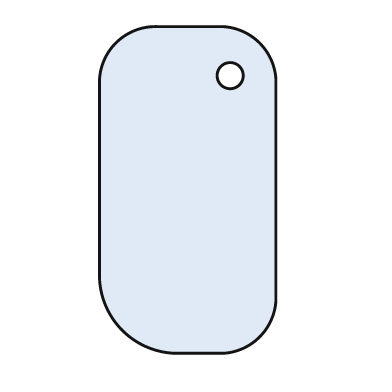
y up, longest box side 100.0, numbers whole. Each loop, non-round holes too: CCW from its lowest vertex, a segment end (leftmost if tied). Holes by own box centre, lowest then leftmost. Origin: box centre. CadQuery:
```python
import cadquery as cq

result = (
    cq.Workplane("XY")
    .moveTo(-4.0, -50.0)
    .lineTo(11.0, -50.0)
    .threePointArc((22.0, -45.0), (27.0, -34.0))
    .lineTo(27.0, 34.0)
    .threePointArc((22.0, 45.0), (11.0, 50.0))
    .lineTo(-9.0, 50.0)
    .threePointArc((-22.0, 45.0), (-27.0, 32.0))
    .lineTo(-27.0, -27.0)
    .threePointArc((-20.0, -43.0), (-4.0, -50.0))
    .close()
    .moveTo(13.0, 35.0)
    .circle(4.0)
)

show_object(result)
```